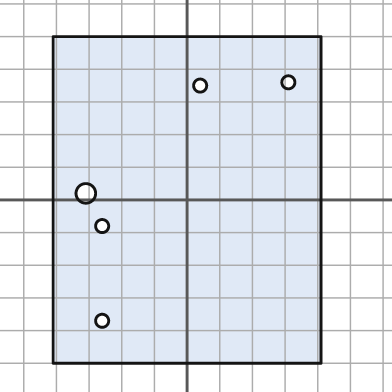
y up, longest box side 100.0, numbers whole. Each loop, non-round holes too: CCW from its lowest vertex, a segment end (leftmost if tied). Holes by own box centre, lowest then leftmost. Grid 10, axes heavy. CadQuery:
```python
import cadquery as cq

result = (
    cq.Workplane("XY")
    .moveTo(-41.0, -50.0)
    .lineTo(41.0, -50.0)
    .lineTo(41.0, 50.0)
    .lineTo(-41.0, 50.0)
    .close()
    .moveTo(-26.0, -37.0)
    .circle(2.0)
    .moveTo(-26.0, -8.0)
    .circle(2.0)
    .moveTo(-31.0, 2.0)
    .circle(3.0)
    .moveTo(4.0, 35.0)
    .circle(2.0)
    .moveTo(31.0, 36.0)
    .circle(2.0)
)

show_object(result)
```